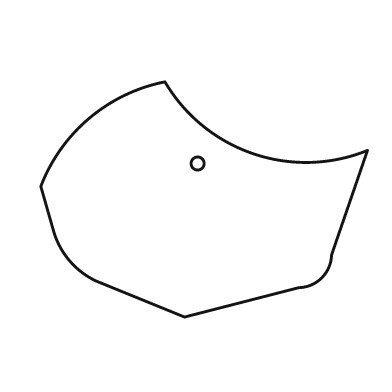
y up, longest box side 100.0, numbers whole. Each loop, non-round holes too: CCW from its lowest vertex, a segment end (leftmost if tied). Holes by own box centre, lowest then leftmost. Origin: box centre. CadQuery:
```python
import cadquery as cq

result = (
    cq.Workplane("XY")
    .moveTo(-6.0, -36.0)
    .lineTo(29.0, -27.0)
    .threePointArc((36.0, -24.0), (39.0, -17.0))
    .lineTo(50.0, 15.0)
    .threePointArc((15.0, 14.0), (-12.0, 36.0))
    .threePointArc((-35.0, 25.0), (-50.0, 4.0))
    .lineTo(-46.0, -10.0)
    .threePointArc((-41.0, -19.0), (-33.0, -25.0))
    .close()
    .moveTo(-2.0, 11.0)
    .circle(2.0)
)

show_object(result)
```